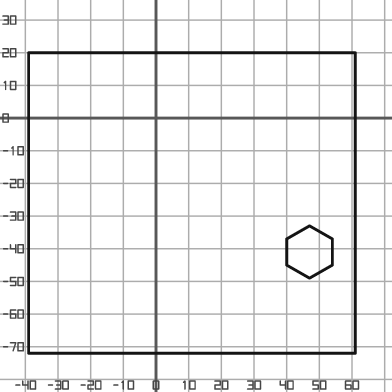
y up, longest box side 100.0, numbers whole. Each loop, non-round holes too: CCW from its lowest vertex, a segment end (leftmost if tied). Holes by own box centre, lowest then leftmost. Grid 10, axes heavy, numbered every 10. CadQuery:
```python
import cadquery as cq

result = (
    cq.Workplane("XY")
    .moveTo(-39.0, -72.0)
    .lineTo(61.0, -72.0)
    .lineTo(61.0, 20.0)
    .lineTo(-39.0, 20.0)
    .close()
    .moveTo(47.0, -49.0)
    .lineTo(54.0, -45.0)
    .lineTo(54.0, -37.0)
    .lineTo(47.0, -33.0)
    .lineTo(40.0, -37.0)
    .lineTo(40.0, -45.0)
    .close()
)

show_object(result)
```